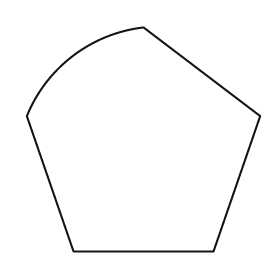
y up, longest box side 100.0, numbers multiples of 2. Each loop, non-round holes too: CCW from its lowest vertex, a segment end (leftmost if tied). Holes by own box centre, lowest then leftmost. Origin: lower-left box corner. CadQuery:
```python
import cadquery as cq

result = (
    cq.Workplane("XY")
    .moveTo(20.0, 0.0)
    .lineTo(80.0, 0.0)
    .lineTo(100.0, 58.0)
    .lineTo(50.0, 96.0)
    .threePointArc((20.0, 84.0), (0.0, 58.0))
    .close()
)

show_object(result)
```